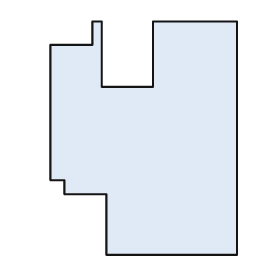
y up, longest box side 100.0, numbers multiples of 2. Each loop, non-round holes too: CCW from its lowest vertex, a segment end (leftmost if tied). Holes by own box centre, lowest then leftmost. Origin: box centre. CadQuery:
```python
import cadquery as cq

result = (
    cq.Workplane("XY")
    .moveTo(-16.0, -50.0)
    .lineTo(40.0, -50.0)
    .lineTo(40.0, 50.0)
    .lineTo(4.0, 50.0)
    .lineTo(4.0, 22.0)
    .lineTo(-18.0, 22.0)
    .lineTo(-18.0, 50.0)
    .lineTo(-22.0, 50.0)
    .lineTo(-22.0, 40.0)
    .lineTo(-40.0, 40.0)
    .lineTo(-40.0, -18.0)
    .lineTo(-34.0, -18.0)
    .lineTo(-34.0, -24.0)
    .lineTo(-16.0, -24.0)
    .close()
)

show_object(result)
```